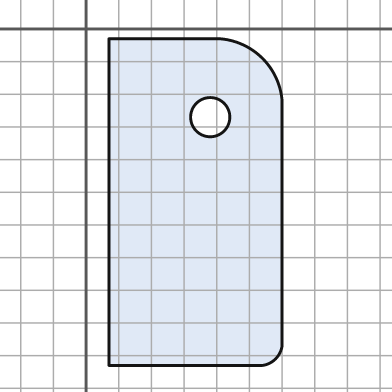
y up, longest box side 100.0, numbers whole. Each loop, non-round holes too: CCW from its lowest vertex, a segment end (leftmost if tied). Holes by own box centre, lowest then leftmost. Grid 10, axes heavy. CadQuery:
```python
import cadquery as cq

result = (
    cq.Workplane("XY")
    .moveTo(7.0, -103.0)
    .lineTo(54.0, -103.0)
    .threePointArc((58.0, -101.0), (60.0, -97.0))
    .lineTo(60.0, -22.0)
    .threePointArc((54.0, -9.0), (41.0, -3.0))
    .lineTo(7.0, -3.0)
    .close()
    .moveTo(38.0, -27.0)
    .circle(6.0)
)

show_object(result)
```